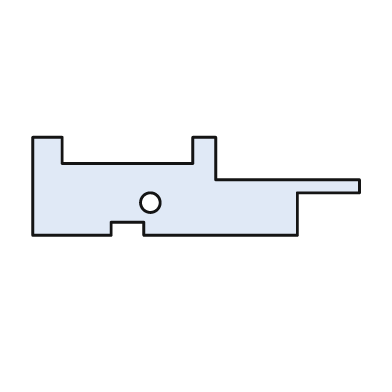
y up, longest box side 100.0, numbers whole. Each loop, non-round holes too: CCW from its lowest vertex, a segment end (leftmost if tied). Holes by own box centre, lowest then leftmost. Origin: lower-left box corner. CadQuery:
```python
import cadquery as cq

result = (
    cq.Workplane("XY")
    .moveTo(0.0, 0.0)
    .lineTo(24.0, 0.0)
    .lineTo(24.0, 4.0)
    .lineTo(34.0, 4.0)
    .lineTo(34.0, 0.0)
    .lineTo(81.0, 0.0)
    .lineTo(81.0, 13.0)
    .lineTo(100.0, 13.0)
    .lineTo(100.0, 17.0)
    .lineTo(56.0, 17.0)
    .lineTo(56.0, 30.0)
    .lineTo(49.0, 30.0)
    .lineTo(49.0, 22.0)
    .lineTo(9.0, 22.0)
    .lineTo(9.0, 30.0)
    .lineTo(0.0, 30.0)
    .close()
    .moveTo(36.0, 10.0)
    .circle(3.0)
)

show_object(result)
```